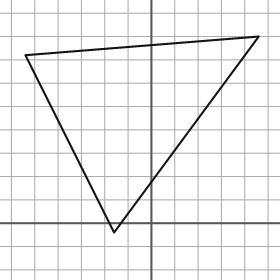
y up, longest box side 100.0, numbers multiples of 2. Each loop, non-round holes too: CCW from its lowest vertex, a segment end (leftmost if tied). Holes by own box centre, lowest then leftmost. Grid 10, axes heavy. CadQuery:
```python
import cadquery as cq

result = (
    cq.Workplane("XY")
    .moveTo(-16.0, -4.0)
    .lineTo(46.0, 80.0)
    .lineTo(-54.0, 72.0)
    .close()
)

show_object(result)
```